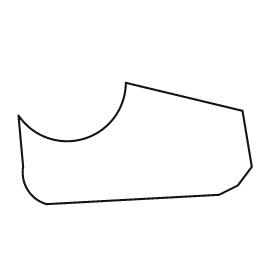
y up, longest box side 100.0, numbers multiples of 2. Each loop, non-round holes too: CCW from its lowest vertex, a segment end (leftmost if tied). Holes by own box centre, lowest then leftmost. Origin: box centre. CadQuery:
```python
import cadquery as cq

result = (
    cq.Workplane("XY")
    .moveTo(-38.0, -26.0)
    .lineTo(36.0, -22.0)
    .lineTo(44.0, -18.0)
    .lineTo(50.0, -10.0)
    .lineTo(46.0, 14.0)
    .lineTo(-4.0, 26.0)
    .threePointArc((-22.0, 2.0), (-50.0, 12.0))
    .lineTo(-48.0, -10.0)
    .threePointArc((-46.0, -20.0), (-38.0, -26.0))
    .close()
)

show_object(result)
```